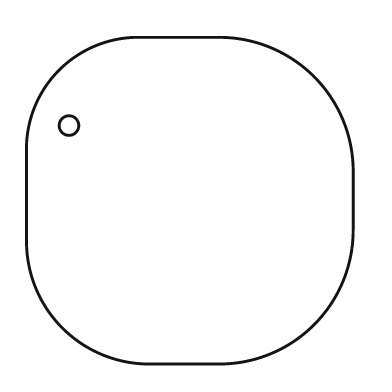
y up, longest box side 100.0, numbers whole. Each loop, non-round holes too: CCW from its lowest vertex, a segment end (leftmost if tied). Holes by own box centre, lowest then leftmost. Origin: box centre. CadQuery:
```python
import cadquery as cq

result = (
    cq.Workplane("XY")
    .moveTo(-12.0, -50.0)
    .lineTo(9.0, -50.0)
    .threePointArc((38.0, -38.0), (50.0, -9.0))
    .lineTo(50.0, 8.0)
    .threePointArc((38.0, 38.0), (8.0, 50.0))
    .lineTo(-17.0, 50.0)
    .threePointArc((-40.0, 40.0), (-50.0, 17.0))
    .lineTo(-50.0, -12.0)
    .threePointArc((-39.0, -39.0), (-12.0, -50.0))
    .close()
    .moveTo(-37.0, 23.0)
    .circle(3.0)
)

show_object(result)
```